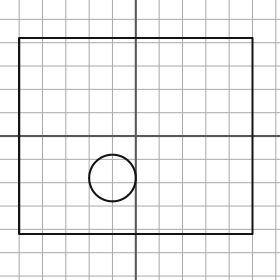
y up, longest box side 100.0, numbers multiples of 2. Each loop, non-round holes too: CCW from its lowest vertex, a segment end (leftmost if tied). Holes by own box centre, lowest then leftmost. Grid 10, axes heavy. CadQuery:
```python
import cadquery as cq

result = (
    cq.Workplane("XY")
    .moveTo(-50.0, -42.0)
    .lineTo(50.0, -42.0)
    .lineTo(50.0, 42.0)
    .lineTo(-50.0, 42.0)
    .close()
    .moveTo(-10.0, -18.0)
    .circle(10.0)
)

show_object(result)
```